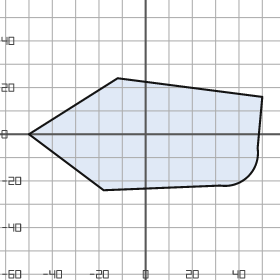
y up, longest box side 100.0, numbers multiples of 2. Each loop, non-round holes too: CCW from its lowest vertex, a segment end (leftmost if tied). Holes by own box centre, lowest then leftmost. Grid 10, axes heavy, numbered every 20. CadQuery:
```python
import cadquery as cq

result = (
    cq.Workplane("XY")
    .moveTo(-18.0, -24.0)
    .lineTo(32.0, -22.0)
    .threePointArc((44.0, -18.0), (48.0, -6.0))
    .lineTo(50.0, 16.0)
    .lineTo(-12.0, 24.0)
    .lineTo(-50.0, 0.0)
    .close()
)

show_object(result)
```